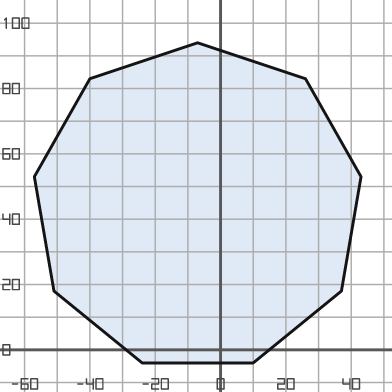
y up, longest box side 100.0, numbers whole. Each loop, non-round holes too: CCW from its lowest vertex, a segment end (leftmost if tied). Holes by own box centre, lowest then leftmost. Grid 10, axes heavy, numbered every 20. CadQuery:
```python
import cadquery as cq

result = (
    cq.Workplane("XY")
    .moveTo(-24.0, -4.0)
    .lineTo(10.0, -4.0)
    .lineTo(37.0, 18.0)
    .lineTo(43.0, 53.0)
    .lineTo(26.0, 83.0)
    .lineTo(-7.0, 94.0)
    .lineTo(-40.0, 83.0)
    .lineTo(-57.0, 53.0)
    .lineTo(-51.0, 18.0)
    .close()
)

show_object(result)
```